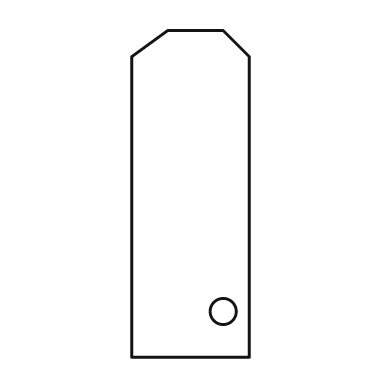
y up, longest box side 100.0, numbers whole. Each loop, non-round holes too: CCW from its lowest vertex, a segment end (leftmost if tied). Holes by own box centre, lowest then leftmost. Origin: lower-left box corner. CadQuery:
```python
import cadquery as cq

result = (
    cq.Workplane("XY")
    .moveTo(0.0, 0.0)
    .lineTo(36.0, 0.0)
    .lineTo(36.0, 92.0)
    .lineTo(28.0, 100.0)
    .lineTo(11.0, 100.0)
    .lineTo(0.0, 92.0)
    .close()
    .moveTo(28.0, 14.0)
    .circle(4.0)
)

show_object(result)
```